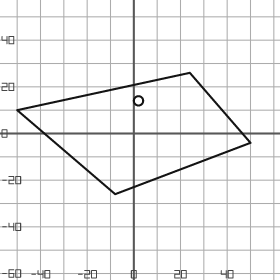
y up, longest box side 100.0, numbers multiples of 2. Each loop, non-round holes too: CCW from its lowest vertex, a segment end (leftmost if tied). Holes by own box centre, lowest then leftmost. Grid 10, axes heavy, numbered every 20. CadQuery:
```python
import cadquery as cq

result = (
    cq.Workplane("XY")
    .moveTo(-8.0, -26.0)
    .lineTo(50.0, -4.0)
    .lineTo(24.0, 26.0)
    .lineTo(-50.0, 10.0)
    .close()
    .moveTo(2.0, 14.0)
    .circle(2.0)
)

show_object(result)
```